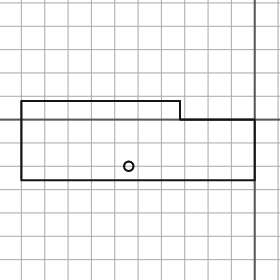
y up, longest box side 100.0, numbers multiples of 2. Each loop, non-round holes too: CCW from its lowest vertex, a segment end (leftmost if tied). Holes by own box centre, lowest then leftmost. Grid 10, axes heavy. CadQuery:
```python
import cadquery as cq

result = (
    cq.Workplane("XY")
    .moveTo(-100.0, -26.0)
    .lineTo(0.0, -26.0)
    .lineTo(0.0, 0.0)
    .lineTo(-32.0, 0.0)
    .lineTo(-32.0, 8.0)
    .lineTo(-100.0, 8.0)
    .close()
    .moveTo(-54.0, -20.0)
    .circle(2.0)
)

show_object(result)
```